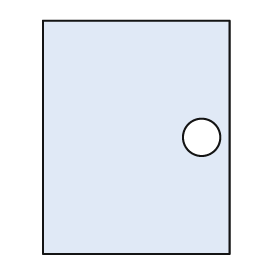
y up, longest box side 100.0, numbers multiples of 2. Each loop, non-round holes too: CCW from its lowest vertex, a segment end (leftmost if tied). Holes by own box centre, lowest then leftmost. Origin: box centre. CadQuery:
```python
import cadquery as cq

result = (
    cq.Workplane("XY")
    .moveTo(-40.0, -50.0)
    .lineTo(40.0, -50.0)
    .lineTo(40.0, 50.0)
    .lineTo(-40.0, 50.0)
    .close()
    .moveTo(28.0, 0.0)
    .circle(8.0)
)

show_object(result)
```